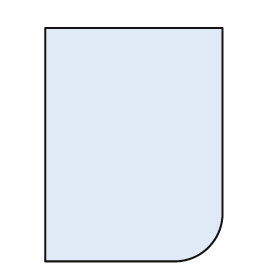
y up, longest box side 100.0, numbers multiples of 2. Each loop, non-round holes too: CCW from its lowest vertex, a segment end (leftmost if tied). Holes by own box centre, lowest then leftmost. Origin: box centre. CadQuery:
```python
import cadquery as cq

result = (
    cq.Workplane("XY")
    .moveTo(-38.0, -50.0)
    .lineTo(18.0, -50.0)
    .threePointArc((32.0, -44.0), (38.0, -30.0))
    .lineTo(38.0, 50.0)
    .lineTo(-38.0, 50.0)
    .close()
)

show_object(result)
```